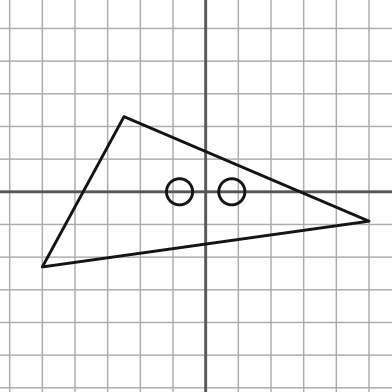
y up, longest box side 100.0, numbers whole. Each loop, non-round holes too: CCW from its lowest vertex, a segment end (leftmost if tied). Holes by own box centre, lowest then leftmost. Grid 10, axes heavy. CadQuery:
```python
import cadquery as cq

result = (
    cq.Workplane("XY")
    .moveTo(-50.0, -23.0)
    .lineTo(50.0, -9.0)
    .lineTo(-25.0, 23.0)
    .close()
    .moveTo(-8.0, 0.0)
    .circle(4.0)
    .moveTo(8.0, 0.0)
    .circle(4.0)
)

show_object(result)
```